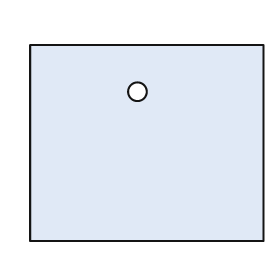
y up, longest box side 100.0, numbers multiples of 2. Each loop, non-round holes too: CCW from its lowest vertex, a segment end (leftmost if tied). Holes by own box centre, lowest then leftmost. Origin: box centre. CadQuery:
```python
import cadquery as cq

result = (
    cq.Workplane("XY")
    .moveTo(-50.0, -42.0)
    .lineTo(50.0, -42.0)
    .lineTo(50.0, 42.0)
    .lineTo(-50.0, 42.0)
    .close()
    .moveTo(-4.0, 22.0)
    .circle(4.0)
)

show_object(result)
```